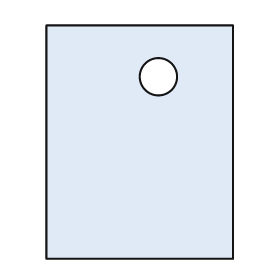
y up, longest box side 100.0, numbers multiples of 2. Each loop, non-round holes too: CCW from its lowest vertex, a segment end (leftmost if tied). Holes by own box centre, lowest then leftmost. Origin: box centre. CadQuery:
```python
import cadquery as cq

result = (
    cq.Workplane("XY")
    .moveTo(-40.0, -50.0)
    .lineTo(40.0, -50.0)
    .lineTo(40.0, 50.0)
    .lineTo(-40.0, 50.0)
    .close()
    .moveTo(8.0, 28.0)
    .circle(8.0)
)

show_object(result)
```